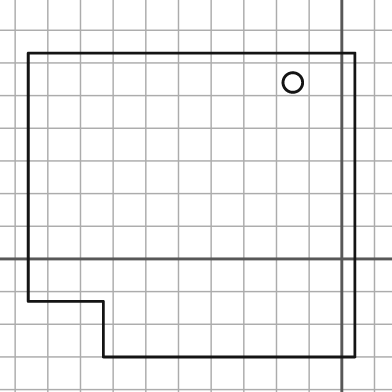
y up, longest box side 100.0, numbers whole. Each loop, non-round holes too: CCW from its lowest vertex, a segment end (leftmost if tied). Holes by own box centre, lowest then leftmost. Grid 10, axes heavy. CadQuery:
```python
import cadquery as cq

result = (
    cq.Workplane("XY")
    .moveTo(-73.0, -30.0)
    .lineTo(4.0, -30.0)
    .lineTo(4.0, 63.0)
    .lineTo(-96.0, 63.0)
    .lineTo(-96.0, -13.0)
    .lineTo(-73.0, -13.0)
    .close()
    .moveTo(-15.0, 54.0)
    .circle(3.0)
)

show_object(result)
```